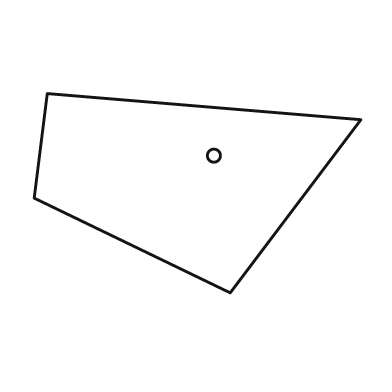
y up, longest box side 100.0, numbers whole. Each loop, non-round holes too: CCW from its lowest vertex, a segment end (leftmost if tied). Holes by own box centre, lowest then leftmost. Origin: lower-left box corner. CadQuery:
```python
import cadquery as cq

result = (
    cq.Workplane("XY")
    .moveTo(60.0, 0.0)
    .lineTo(100.0, 53.0)
    .lineTo(4.0, 61.0)
    .lineTo(0.0, 29.0)
    .close()
    .moveTo(55.0, 42.0)
    .circle(2.0)
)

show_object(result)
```